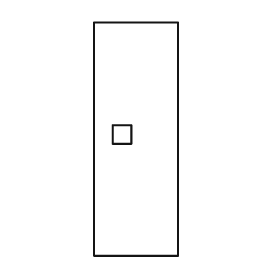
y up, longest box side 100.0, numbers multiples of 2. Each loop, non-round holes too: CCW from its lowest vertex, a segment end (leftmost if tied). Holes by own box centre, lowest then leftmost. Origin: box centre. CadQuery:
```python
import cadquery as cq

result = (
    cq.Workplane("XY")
    .moveTo(-18.0, -50.0)
    .lineTo(18.0, -50.0)
    .lineTo(18.0, 50.0)
    .lineTo(-18.0, 50.0)
    .close()
    .moveTo(-10.0, -2.0)
    .lineTo(-2.0, -2.0)
    .lineTo(-2.0, 6.0)
    .lineTo(-10.0, 6.0)
    .close()
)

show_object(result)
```